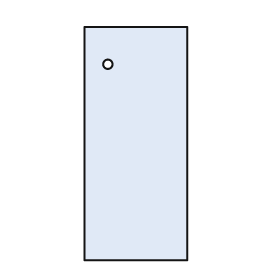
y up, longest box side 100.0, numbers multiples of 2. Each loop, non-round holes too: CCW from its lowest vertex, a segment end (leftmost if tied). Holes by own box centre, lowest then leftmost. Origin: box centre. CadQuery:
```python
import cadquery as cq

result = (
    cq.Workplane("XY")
    .moveTo(-22.0, -50.0)
    .lineTo(22.0, -50.0)
    .lineTo(22.0, 50.0)
    .lineTo(-22.0, 50.0)
    .close()
    .moveTo(-12.0, 34.0)
    .circle(2.0)
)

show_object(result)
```